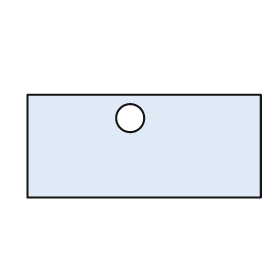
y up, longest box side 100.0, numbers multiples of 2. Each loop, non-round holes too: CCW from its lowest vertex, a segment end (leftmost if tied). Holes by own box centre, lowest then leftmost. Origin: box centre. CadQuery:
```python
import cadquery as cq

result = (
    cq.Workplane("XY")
    .moveTo(-50.0, -22.0)
    .lineTo(50.0, -22.0)
    .lineTo(50.0, 22.0)
    .lineTo(-50.0, 22.0)
    .close()
    .moveTo(-6.0, 12.0)
    .circle(6.0)
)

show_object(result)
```